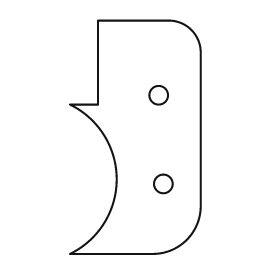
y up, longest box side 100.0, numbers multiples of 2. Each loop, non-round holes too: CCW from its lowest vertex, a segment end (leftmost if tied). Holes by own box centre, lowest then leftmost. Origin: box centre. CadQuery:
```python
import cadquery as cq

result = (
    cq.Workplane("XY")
    .moveTo(-28.0, -50.0)
    .lineTo(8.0, -50.0)
    .threePointArc((22.0, -44.0), (28.0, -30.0))
    .lineTo(28.0, 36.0)
    .threePointArc((24.0, 46.0), (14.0, 50.0))
    .lineTo(-16.0, 50.0)
    .lineTo(-16.0, 14.0)
    .lineTo(-28.0, 14.0)
    .threePointArc((-8.0, -18.0), (-28.0, -50.0))
    .close()
    .moveTo(12.0, -20.0)
    .circle(4.0)
    .moveTo(10.0, 18.0)
    .circle(4.0)
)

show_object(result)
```